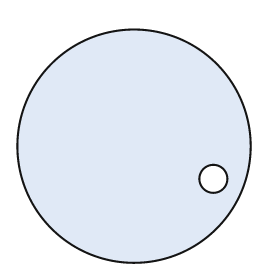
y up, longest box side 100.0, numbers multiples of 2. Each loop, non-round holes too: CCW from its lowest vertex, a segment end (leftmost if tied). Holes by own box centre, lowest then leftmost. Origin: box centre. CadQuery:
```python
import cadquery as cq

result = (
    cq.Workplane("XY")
    .moveTo(0.0, 0.0)
    .circle(50.0)
    .moveTo(34.0, -14.0)
    .circle(6.0)
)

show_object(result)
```